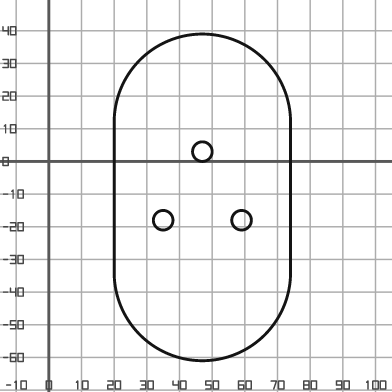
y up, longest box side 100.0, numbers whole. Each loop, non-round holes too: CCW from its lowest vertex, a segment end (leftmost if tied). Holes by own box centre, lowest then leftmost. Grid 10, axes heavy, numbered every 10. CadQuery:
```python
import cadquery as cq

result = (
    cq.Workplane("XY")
    .moveTo(20.0, -34.0)
    .threePointArc((47.0, -61.0), (74.0, -34.0))
    .lineTo(74.0, 12.0)
    .threePointArc((47.0, 39.0), (20.0, 12.0))
    .close()
    .moveTo(35.0, -18.0)
    .circle(3.0)
    .moveTo(59.0, -18.0)
    .circle(3.0)
    .moveTo(47.0, 3.0)
    .circle(3.0)
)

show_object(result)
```